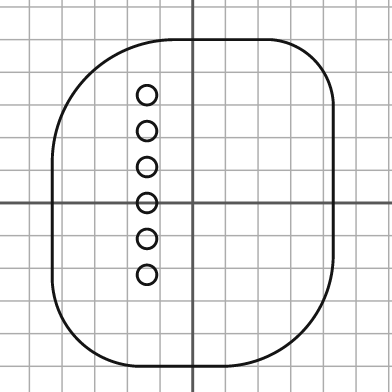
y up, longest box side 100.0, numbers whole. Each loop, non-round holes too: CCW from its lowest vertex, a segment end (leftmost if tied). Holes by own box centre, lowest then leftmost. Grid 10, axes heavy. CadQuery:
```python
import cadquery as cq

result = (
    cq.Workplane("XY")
    .moveTo(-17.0, -50.0)
    .lineTo(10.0, -50.0)
    .threePointArc((33.0, -40.0), (43.0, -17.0))
    .lineTo(43.0, 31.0)
    .threePointArc((37.0, 44.0), (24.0, 50.0))
    .lineTo(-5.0, 50.0)
    .threePointArc((-32.0, 39.0), (-43.0, 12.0))
    .lineTo(-43.0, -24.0)
    .threePointArc((-35.0, -42.0), (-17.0, -50.0))
    .close()
    .moveTo(-14.0, -22.0)
    .circle(3.0)
    .moveTo(-14.0, -11.0)
    .circle(3.0)
    .moveTo(-14.0, 0.0)
    .circle(3.0)
    .moveTo(-14.0, 11.0)
    .circle(3.0)
    .moveTo(-14.0, 22.0)
    .circle(3.0)
    .moveTo(-14.0, 33.0)
    .circle(3.0)
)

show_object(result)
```